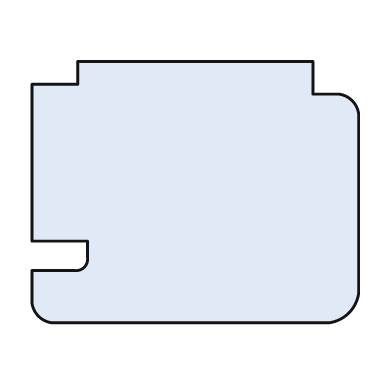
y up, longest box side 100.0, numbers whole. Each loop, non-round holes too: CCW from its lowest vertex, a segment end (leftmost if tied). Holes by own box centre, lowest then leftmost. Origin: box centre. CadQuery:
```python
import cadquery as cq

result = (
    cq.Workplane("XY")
    .moveTo(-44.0, -40.0)
    .lineTo(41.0, -40.0)
    .threePointArc((47.0, -37.0), (50.0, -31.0))
    .lineTo(50.0, 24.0)
    .threePointArc((48.0, 28.0), (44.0, 30.0))
    .lineTo(36.0, 30.0)
    .lineTo(36.0, 40.0)
    .lineTo(-36.0, 40.0)
    .lineTo(-36.0, 33.0)
    .lineTo(-50.0, 33.0)
    .lineTo(-50.0, -15.0)
    .lineTo(-33.0, -15.0)
    .lineTo(-33.0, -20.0)
    .threePointArc((-34.0, -23.0), (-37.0, -24.0))
    .lineTo(-50.0, -24.0)
    .lineTo(-50.0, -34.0)
    .threePointArc((-48.0, -38.0), (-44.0, -40.0))
    .close()
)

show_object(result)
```